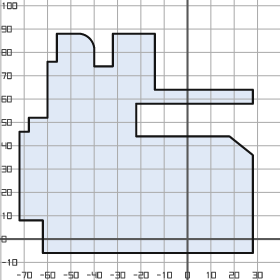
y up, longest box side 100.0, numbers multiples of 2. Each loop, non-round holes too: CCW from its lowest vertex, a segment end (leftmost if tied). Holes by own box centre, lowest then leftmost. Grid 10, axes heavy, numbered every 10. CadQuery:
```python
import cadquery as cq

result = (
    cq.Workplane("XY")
    .moveTo(-62.0, -6.0)
    .lineTo(28.0, -6.0)
    .lineTo(28.0, 36.0)
    .lineTo(18.0, 44.0)
    .lineTo(-22.0, 44.0)
    .lineTo(-22.0, 58.0)
    .lineTo(28.0, 58.0)
    .lineTo(28.0, 64.0)
    .lineTo(-14.0, 64.0)
    .lineTo(-14.0, 88.0)
    .lineTo(-32.0, 88.0)
    .lineTo(-32.0, 74.0)
    .lineTo(-40.0, 74.0)
    .lineTo(-40.0, 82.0)
    .threePointArc((-42.0, 86.0), (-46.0, 88.0))
    .lineTo(-56.0, 88.0)
    .lineTo(-56.0, 76.0)
    .lineTo(-60.0, 76.0)
    .lineTo(-60.0, 52.0)
    .lineTo(-68.0, 52.0)
    .lineTo(-68.0, 46.0)
    .lineTo(-72.0, 46.0)
    .lineTo(-72.0, 8.0)
    .lineTo(-62.0, 8.0)
    .close()
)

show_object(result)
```